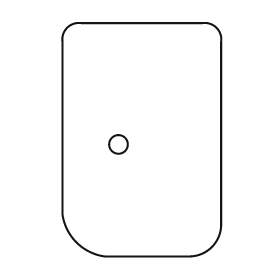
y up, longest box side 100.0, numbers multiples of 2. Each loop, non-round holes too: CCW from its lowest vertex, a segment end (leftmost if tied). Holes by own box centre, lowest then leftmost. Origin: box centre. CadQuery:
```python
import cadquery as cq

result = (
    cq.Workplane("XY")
    .moveTo(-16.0, -50.0)
    .lineTo(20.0, -50.0)
    .threePointArc((30.0, -46.0), (34.0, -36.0))
    .lineTo(34.0, 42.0)
    .threePointArc((32.0, 48.0), (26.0, 50.0))
    .lineTo(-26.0, 50.0)
    .threePointArc((-32.0, 48.0), (-34.0, 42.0))
    .lineTo(-34.0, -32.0)
    .threePointArc((-28.0, -44.0), (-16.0, -50.0))
    .close()
    .moveTo(-10.0, -2.0)
    .circle(4.0)
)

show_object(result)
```